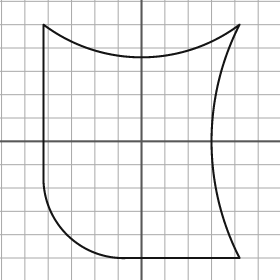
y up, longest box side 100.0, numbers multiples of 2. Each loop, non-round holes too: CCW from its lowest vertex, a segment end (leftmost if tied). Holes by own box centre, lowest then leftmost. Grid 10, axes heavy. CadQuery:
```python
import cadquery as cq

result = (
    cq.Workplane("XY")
    .moveTo(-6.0, -50.0)
    .lineTo(42.0, -50.0)
    .threePointArc((30.0, 0.0), (42.0, 50.0))
    .threePointArc((0.0, 36.0), (-42.0, 50.0))
    .lineTo(-42.0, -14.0)
    .threePointArc((-32.0, -40.0), (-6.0, -50.0))
    .close()
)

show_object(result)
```